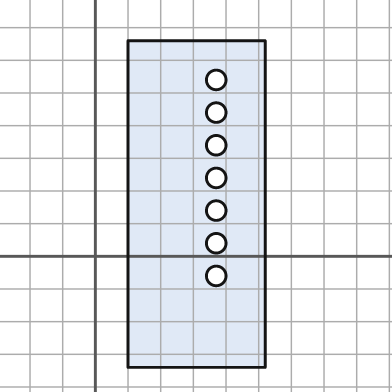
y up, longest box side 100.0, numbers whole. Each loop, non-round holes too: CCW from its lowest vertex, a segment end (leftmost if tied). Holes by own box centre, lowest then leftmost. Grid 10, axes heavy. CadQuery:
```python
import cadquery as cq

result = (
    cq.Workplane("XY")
    .moveTo(10.0, -34.0)
    .lineTo(52.0, -34.0)
    .lineTo(52.0, 66.0)
    .lineTo(10.0, 66.0)
    .close()
    .moveTo(37.0, -6.0)
    .circle(3.0)
    .moveTo(37.0, 4.0)
    .circle(3.0)
    .moveTo(37.0, 14.0)
    .circle(3.0)
    .moveTo(37.0, 24.0)
    .circle(3.0)
    .moveTo(37.0, 34.0)
    .circle(3.0)
    .moveTo(37.0, 44.0)
    .circle(3.0)
    .moveTo(37.0, 54.0)
    .circle(3.0)
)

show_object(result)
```